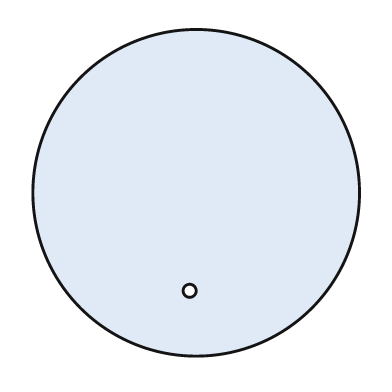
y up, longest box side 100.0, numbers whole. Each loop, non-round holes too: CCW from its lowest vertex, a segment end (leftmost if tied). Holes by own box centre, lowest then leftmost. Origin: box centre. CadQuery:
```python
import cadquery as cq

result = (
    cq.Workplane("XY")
    .moveTo(0.0, 0.0)
    .circle(50.0)
    .moveTo(-2.0, -30.0)
    .circle(2.0)
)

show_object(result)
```